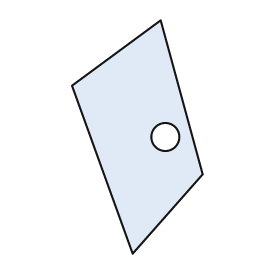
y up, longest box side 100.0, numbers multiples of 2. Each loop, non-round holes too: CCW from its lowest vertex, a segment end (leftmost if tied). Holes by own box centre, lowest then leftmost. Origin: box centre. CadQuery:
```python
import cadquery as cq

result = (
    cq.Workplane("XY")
    .moveTo(-2.0, -50.0)
    .lineTo(28.0, -16.0)
    .lineTo(10.0, 50.0)
    .lineTo(-28.0, 22.0)
    .close()
    .moveTo(12.0, 0.0)
    .circle(6.0)
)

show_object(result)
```